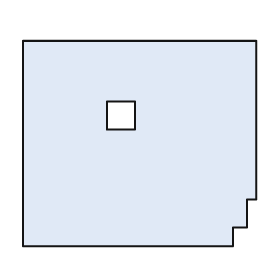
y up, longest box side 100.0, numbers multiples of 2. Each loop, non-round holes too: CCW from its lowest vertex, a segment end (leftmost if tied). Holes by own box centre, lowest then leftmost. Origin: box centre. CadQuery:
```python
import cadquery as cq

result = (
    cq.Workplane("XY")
    .moveTo(-50.0, -44.0)
    .lineTo(40.0, -44.0)
    .lineTo(40.0, -36.0)
    .lineTo(46.0, -36.0)
    .lineTo(46.0, -24.0)
    .lineTo(50.0, -24.0)
    .lineTo(50.0, 44.0)
    .lineTo(-50.0, 44.0)
    .close()
    .moveTo(-14.0, 6.0)
    .lineTo(-2.0, 6.0)
    .lineTo(-2.0, 18.0)
    .lineTo(-14.0, 18.0)
    .close()
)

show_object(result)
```